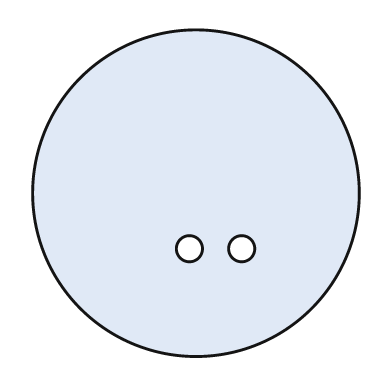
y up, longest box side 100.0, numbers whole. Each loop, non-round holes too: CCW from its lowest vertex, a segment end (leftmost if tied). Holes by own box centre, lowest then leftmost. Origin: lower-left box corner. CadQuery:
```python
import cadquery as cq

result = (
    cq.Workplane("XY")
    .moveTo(50.0, 50.0)
    .circle(50.0)
    .moveTo(48.0, 33.0)
    .circle(4.0)
    .moveTo(64.0, 33.0)
    .circle(4.0)
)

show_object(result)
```